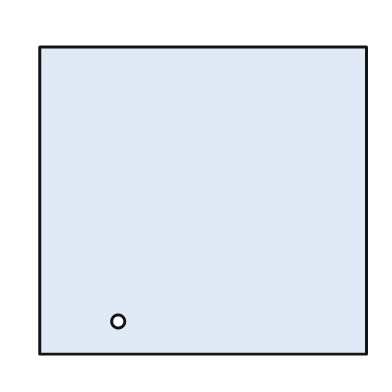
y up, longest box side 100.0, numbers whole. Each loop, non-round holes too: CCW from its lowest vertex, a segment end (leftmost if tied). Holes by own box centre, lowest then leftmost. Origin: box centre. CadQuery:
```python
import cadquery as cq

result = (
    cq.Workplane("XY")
    .moveTo(-50.0, -47.0)
    .lineTo(50.0, -47.0)
    .lineTo(50.0, 47.0)
    .lineTo(-50.0, 47.0)
    .close()
    .moveTo(-26.0, -37.0)
    .circle(2.0)
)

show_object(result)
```